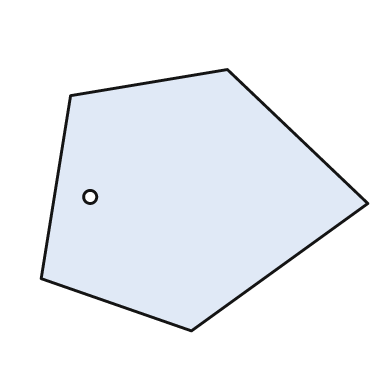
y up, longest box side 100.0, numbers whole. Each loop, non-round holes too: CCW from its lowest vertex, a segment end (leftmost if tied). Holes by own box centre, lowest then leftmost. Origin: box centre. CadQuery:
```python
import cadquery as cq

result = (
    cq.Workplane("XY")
    .moveTo(-4.0, -40.0)
    .lineTo(50.0, -1.0)
    .lineTo(7.0, 40.0)
    .lineTo(-41.0, 32.0)
    .lineTo(-50.0, -24.0)
    .close()
    .moveTo(-35.0, 1.0)
    .circle(2.0)
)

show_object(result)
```